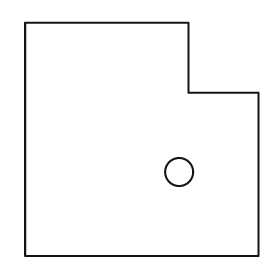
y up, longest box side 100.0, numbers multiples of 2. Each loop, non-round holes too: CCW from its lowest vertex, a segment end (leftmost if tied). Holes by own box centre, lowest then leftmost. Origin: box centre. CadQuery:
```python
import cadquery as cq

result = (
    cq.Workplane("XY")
    .moveTo(-50.0, -50.0)
    .lineTo(50.0, -50.0)
    .lineTo(50.0, 20.0)
    .lineTo(20.0, 20.0)
    .lineTo(20.0, 50.0)
    .lineTo(-50.0, 50.0)
    .close()
    .moveTo(16.0, -14.0)
    .circle(6.0)
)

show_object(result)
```